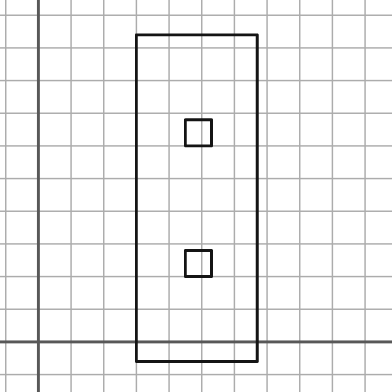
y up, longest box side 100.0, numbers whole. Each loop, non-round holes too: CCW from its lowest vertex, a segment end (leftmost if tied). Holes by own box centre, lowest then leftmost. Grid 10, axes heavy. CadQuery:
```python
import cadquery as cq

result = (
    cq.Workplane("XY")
    .moveTo(30.0, -6.0)
    .lineTo(67.0, -6.0)
    .lineTo(67.0, 94.0)
    .lineTo(30.0, 94.0)
    .close()
    .moveTo(45.0, 20.0)
    .lineTo(53.0, 20.0)
    .lineTo(53.0, 28.0)
    .lineTo(45.0, 28.0)
    .close()
    .moveTo(45.0, 60.0)
    .lineTo(53.0, 60.0)
    .lineTo(53.0, 68.0)
    .lineTo(45.0, 68.0)
    .close()
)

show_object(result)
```